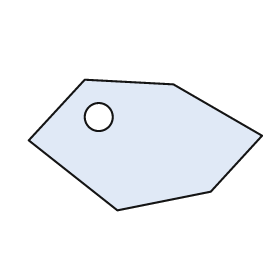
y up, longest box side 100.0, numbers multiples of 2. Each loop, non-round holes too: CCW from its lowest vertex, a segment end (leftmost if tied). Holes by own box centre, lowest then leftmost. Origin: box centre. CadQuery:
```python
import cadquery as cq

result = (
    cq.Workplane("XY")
    .moveTo(-12.0, -28.0)
    .lineTo(28.0, -20.0)
    .lineTo(50.0, 4.0)
    .lineTo(12.0, 26.0)
    .lineTo(-26.0, 28.0)
    .lineTo(-50.0, 2.0)
    .close()
    .moveTo(-20.0, 12.0)
    .circle(6.0)
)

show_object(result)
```